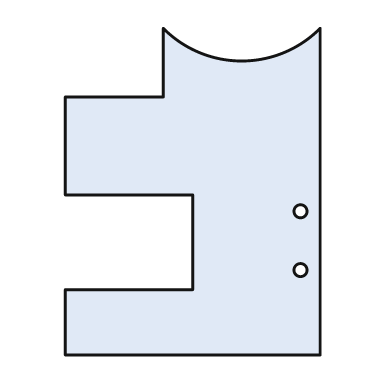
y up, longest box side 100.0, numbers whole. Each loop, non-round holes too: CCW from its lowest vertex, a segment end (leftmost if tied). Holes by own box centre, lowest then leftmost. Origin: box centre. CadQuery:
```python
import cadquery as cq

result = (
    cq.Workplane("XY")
    .moveTo(-39.0, -50.0)
    .lineTo(39.0, -50.0)
    .lineTo(39.0, 50.0)
    .threePointArc((15.0, 40.0), (-9.0, 50.0))
    .lineTo(-9.0, 29.0)
    .lineTo(-39.0, 29.0)
    .lineTo(-39.0, -1.0)
    .lineTo(0.0, -1.0)
    .lineTo(0.0, -30.0)
    .lineTo(-39.0, -30.0)
    .close()
    .moveTo(33.0, -24.0)
    .circle(2.0)
    .moveTo(33.0, -6.0)
    .circle(2.0)
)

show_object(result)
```